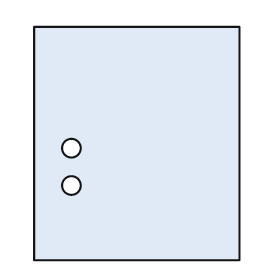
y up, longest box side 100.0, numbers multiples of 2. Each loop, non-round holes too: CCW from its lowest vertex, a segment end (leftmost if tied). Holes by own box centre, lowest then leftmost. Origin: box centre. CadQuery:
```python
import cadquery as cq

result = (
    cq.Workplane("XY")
    .moveTo(-44.0, -50.0)
    .lineTo(44.0, -50.0)
    .lineTo(44.0, 50.0)
    .lineTo(-44.0, 50.0)
    .close()
    .moveTo(-28.0, -18.0)
    .circle(4.0)
    .moveTo(-28.0, -2.0)
    .circle(4.0)
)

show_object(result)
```